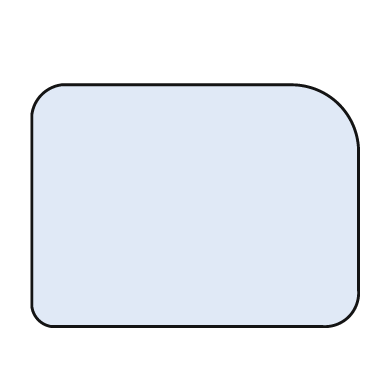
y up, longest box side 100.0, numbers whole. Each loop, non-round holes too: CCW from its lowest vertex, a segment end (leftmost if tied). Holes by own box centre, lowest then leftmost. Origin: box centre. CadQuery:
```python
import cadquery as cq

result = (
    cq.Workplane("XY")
    .moveTo(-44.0, -37.0)
    .lineTo(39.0, -37.0)
    .threePointArc((47.0, -34.0), (50.0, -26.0))
    .lineTo(50.0, 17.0)
    .threePointArc((44.0, 31.0), (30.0, 37.0))
    .lineTo(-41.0, 37.0)
    .threePointArc((-47.0, 34.0), (-50.0, 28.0))
    .lineTo(-50.0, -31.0)
    .threePointArc((-48.0, -35.0), (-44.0, -37.0))
    .close()
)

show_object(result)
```